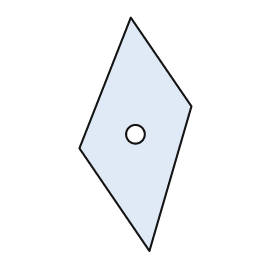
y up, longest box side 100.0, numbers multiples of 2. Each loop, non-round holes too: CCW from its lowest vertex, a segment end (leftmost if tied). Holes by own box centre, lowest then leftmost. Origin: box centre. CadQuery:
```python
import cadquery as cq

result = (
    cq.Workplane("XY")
    .moveTo(6.0, -50.0)
    .lineTo(24.0, 12.0)
    .lineTo(-2.0, 50.0)
    .lineTo(-24.0, -6.0)
    .close()
    .moveTo(0.0, 0.0)
    .circle(4.0)
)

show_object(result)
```